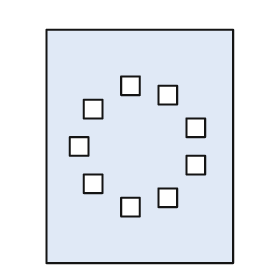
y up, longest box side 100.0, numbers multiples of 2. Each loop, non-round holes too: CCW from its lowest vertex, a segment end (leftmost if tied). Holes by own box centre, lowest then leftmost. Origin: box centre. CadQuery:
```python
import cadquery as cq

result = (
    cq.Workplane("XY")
    .moveTo(-40.0, -50.0)
    .lineTo(40.0, -50.0)
    .lineTo(40.0, 50.0)
    .lineTo(-40.0, 50.0)
    .close()
    .moveTo(-8.0, -30.0)
    .lineTo(0.0, -30.0)
    .lineTo(0.0, -22.0)
    .lineTo(-8.0, -22.0)
    .close()
    .moveTo(8.0, -26.0)
    .lineTo(16.0, -26.0)
    .lineTo(16.0, -18.0)
    .lineTo(8.0, -18.0)
    .close()
    .moveTo(-24.0, -20.0)
    .lineTo(-16.0, -20.0)
    .lineTo(-16.0, -12.0)
    .lineTo(-24.0, -12.0)
    .close()
    .moveTo(20.0, -12.0)
    .lineTo(28.0, -12.0)
    .lineTo(28.0, -4.0)
    .lineTo(20.0, -4.0)
    .close()
    .moveTo(-30.0, -4.0)
    .lineTo(-22.0, -4.0)
    .lineTo(-22.0, 4.0)
    .lineTo(-30.0, 4.0)
    .close()
    .moveTo(20.0, 4.0)
    .lineTo(28.0, 4.0)
    .lineTo(28.0, 12.0)
    .lineTo(20.0, 12.0)
    .close()
    .moveTo(-24.0, 12.0)
    .lineTo(-16.0, 12.0)
    .lineTo(-16.0, 20.0)
    .lineTo(-24.0, 20.0)
    .close()
    .moveTo(8.0, 18.0)
    .lineTo(16.0, 18.0)
    .lineTo(16.0, 26.0)
    .lineTo(8.0, 26.0)
    .close()
    .moveTo(-8.0, 22.0)
    .lineTo(0.0, 22.0)
    .lineTo(0.0, 30.0)
    .lineTo(-8.0, 30.0)
    .close()
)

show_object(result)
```